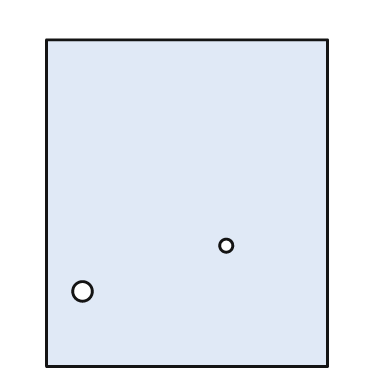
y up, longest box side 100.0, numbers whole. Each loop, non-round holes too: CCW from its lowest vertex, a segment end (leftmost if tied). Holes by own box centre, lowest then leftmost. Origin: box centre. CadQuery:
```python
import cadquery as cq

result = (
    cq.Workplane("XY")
    .moveTo(-43.0, -50.0)
    .lineTo(43.0, -50.0)
    .lineTo(43.0, 50.0)
    .lineTo(-43.0, 50.0)
    .close()
    .moveTo(-32.0, -27.0)
    .circle(3.0)
    .moveTo(12.0, -13.0)
    .circle(2.0)
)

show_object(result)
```